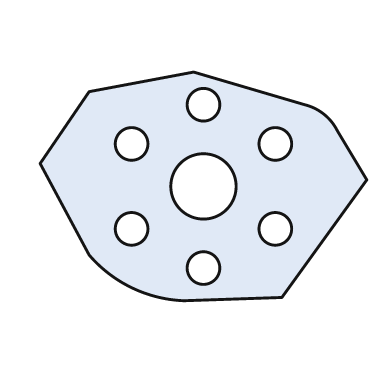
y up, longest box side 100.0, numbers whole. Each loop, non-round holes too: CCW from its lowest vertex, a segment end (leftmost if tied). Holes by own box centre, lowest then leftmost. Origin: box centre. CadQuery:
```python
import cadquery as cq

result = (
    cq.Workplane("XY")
    .moveTo(-6.0, -35.0)
    .lineTo(24.0, -34.0)
    .lineTo(50.0, 2.0)
    .lineTo(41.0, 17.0)
    .threePointArc((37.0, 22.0), (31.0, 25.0))
    .lineTo(-3.0, 35.0)
    .lineTo(-35.0, 29.0)
    .lineTo(-50.0, 7.0)
    .lineTo(-35.0, -21.0)
    .threePointArc((-22.0, -31.0), (-6.0, -35.0))
    .close()
    .moveTo(0.0, -25.0)
    .circle(5.0)
    .moveTo(-22.0, -13.0)
    .circle(5.0)
    .moveTo(22.0, -13.0)
    .circle(5.0)
    .moveTo(0.0, 0.0)
    .circle(10.0)
    .moveTo(-22.0, 13.0)
    .circle(5.0)
    .moveTo(22.0, 13.0)
    .circle(5.0)
    .moveTo(0.0, 25.0)
    .circle(5.0)
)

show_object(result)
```